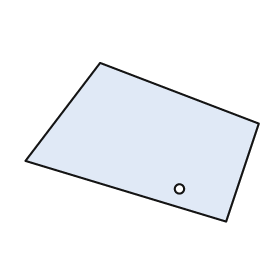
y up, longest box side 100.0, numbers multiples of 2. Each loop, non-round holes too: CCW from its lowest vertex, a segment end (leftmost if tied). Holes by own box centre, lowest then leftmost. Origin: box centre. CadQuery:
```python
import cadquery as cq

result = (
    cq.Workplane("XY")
    .moveTo(36.0, -34.0)
    .lineTo(50.0, 8.0)
    .lineTo(-18.0, 34.0)
    .lineTo(-50.0, -8.0)
    .close()
    .moveTo(16.0, -20.0)
    .circle(2.0)
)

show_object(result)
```